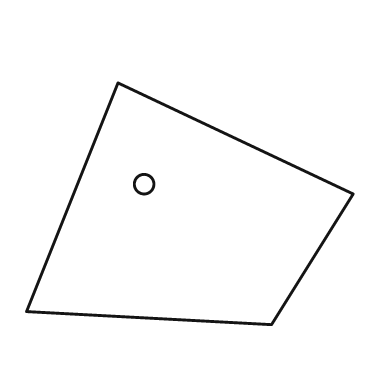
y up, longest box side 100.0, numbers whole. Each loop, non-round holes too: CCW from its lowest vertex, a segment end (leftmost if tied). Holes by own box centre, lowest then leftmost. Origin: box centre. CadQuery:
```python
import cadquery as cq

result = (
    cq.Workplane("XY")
    .moveTo(25.0, -37.0)
    .lineTo(50.0, 3.0)
    .lineTo(-22.0, 37.0)
    .lineTo(-50.0, -33.0)
    .close()
    .moveTo(-14.0, 6.0)
    .circle(3.0)
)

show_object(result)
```